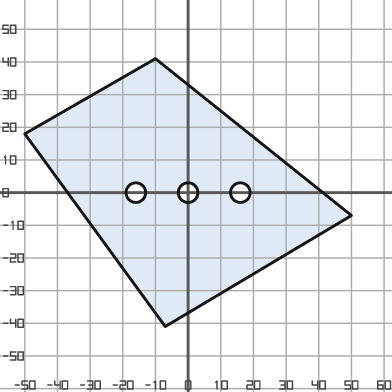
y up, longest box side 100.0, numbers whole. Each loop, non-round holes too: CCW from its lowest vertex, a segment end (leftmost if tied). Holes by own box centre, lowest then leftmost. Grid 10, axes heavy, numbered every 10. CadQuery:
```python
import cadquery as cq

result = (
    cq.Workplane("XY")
    .moveTo(-7.0, -41.0)
    .lineTo(50.0, -7.0)
    .lineTo(-10.0, 41.0)
    .lineTo(-50.0, 18.0)
    .close()
    .moveTo(-16.0, 0.0)
    .circle(3.0)
    .moveTo(0.0, 0.0)
    .circle(3.0)
    .moveTo(16.0, 0.0)
    .circle(3.0)
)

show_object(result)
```